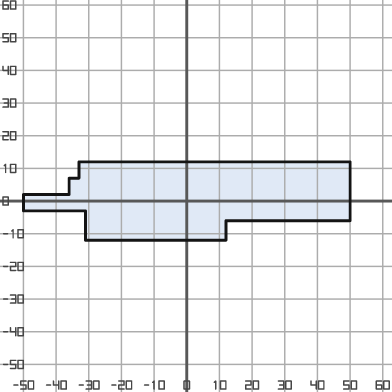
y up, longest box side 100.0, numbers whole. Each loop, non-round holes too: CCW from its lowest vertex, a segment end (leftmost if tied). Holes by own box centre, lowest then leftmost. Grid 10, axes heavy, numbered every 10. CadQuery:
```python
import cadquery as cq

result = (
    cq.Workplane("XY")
    .moveTo(-31.0, -12.0)
    .lineTo(12.0, -12.0)
    .lineTo(12.0, -6.0)
    .lineTo(50.0, -6.0)
    .lineTo(50.0, 12.0)
    .lineTo(-33.0, 12.0)
    .lineTo(-33.0, 7.0)
    .lineTo(-36.0, 7.0)
    .lineTo(-36.0, 2.0)
    .lineTo(-50.0, 2.0)
    .lineTo(-50.0, -3.0)
    .lineTo(-31.0, -3.0)
    .close()
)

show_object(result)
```